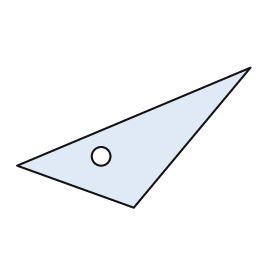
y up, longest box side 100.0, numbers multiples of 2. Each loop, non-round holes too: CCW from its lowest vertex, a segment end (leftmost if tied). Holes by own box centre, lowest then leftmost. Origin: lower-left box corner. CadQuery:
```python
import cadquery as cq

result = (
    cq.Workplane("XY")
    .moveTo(50.0, 0.0)
    .lineTo(100.0, 60.0)
    .lineTo(0.0, 18.0)
    .close()
    .moveTo(36.0, 22.0)
    .circle(4.0)
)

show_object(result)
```